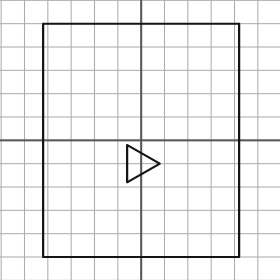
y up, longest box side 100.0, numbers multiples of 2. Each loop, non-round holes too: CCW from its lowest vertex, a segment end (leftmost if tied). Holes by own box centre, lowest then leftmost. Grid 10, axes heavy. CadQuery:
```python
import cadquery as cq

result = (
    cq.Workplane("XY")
    .moveTo(-42.0, -50.0)
    .lineTo(42.0, -50.0)
    .lineTo(42.0, 50.0)
    .lineTo(-42.0, 50.0)
    .close()
    .moveTo(-6.0, -18.0)
    .lineTo(8.0, -10.0)
    .lineTo(-6.0, -2.0)
    .close()
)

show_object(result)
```